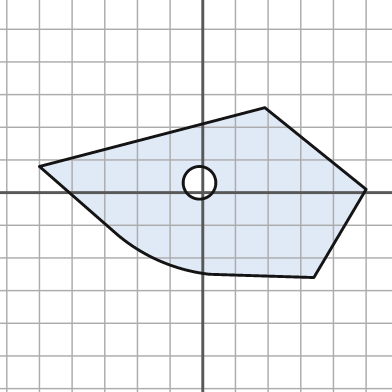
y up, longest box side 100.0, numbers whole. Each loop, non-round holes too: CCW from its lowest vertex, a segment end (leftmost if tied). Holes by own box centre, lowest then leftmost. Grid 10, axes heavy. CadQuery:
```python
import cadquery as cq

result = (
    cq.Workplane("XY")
    .moveTo(34.0, -26.0)
    .lineTo(50.0, 1.0)
    .lineTo(19.0, 26.0)
    .lineTo(-50.0, 8.0)
    .lineTo(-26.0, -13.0)
    .threePointArc((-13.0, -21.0), (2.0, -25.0))
    .close()
    .moveTo(-1.0, 3.0)
    .circle(5.0)
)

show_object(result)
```